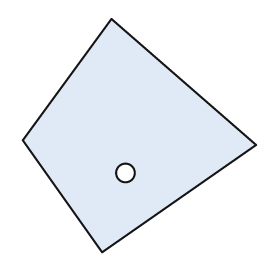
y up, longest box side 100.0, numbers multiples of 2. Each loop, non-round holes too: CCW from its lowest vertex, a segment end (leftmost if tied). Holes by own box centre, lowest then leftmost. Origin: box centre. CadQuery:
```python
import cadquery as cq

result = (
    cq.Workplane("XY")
    .moveTo(-16.0, -50.0)
    .lineTo(50.0, -4.0)
    .lineTo(-12.0, 50.0)
    .lineTo(-50.0, -2.0)
    .close()
    .moveTo(-6.0, -16.0)
    .circle(4.0)
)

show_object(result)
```